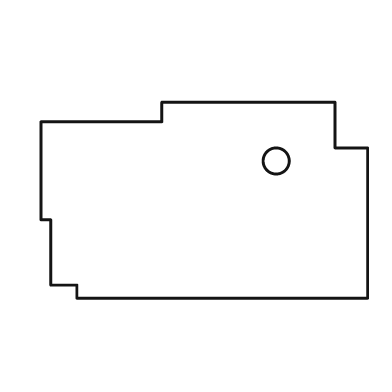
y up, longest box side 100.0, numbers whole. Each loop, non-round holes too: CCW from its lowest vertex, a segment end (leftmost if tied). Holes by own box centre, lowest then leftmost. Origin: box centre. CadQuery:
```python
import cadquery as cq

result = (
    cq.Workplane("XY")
    .moveTo(-39.0, -30.0)
    .lineTo(50.0, -30.0)
    .lineTo(50.0, 16.0)
    .lineTo(40.0, 16.0)
    .lineTo(40.0, 30.0)
    .lineTo(-13.0, 30.0)
    .lineTo(-13.0, 24.0)
    .lineTo(-50.0, 24.0)
    .lineTo(-50.0, -6.0)
    .lineTo(-47.0, -6.0)
    .lineTo(-47.0, -26.0)
    .lineTo(-39.0, -26.0)
    .close()
    .moveTo(22.0, 12.0)
    .circle(4.0)
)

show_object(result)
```